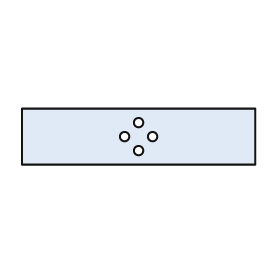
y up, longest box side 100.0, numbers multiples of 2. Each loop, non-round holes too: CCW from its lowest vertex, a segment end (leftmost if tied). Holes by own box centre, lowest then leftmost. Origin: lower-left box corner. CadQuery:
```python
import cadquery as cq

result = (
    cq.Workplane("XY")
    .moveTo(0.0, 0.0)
    .lineTo(100.0, 0.0)
    .lineTo(100.0, 24.0)
    .lineTo(0.0, 24.0)
    .close()
    .moveTo(50.0, 6.0)
    .circle(2.0)
    .moveTo(44.0, 12.0)
    .circle(2.0)
    .moveTo(56.0, 12.0)
    .circle(2.0)
    .moveTo(50.0, 18.0)
    .circle(2.0)
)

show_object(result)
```